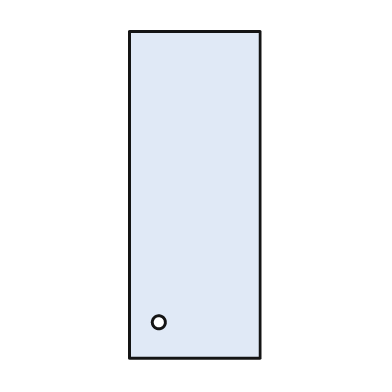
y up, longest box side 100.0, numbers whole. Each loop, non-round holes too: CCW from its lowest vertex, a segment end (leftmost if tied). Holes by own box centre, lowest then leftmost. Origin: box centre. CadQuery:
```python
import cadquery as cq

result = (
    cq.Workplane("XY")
    .moveTo(-20.0, -50.0)
    .lineTo(20.0, -50.0)
    .lineTo(20.0, 50.0)
    .lineTo(-20.0, 50.0)
    .close()
    .moveTo(-11.0, -39.0)
    .circle(2.0)
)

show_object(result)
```